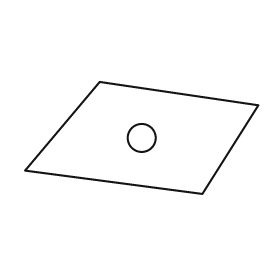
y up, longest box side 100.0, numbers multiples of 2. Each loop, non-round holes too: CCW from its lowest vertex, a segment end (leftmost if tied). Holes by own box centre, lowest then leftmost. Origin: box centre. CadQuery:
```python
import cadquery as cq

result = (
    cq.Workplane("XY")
    .moveTo(26.0, -24.0)
    .lineTo(50.0, 14.0)
    .lineTo(-18.0, 24.0)
    .lineTo(-50.0, -14.0)
    .close()
    .moveTo(0.0, 0.0)
    .circle(6.0)
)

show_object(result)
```